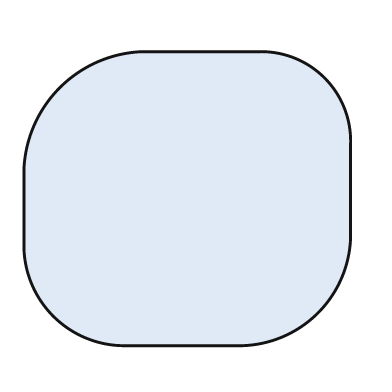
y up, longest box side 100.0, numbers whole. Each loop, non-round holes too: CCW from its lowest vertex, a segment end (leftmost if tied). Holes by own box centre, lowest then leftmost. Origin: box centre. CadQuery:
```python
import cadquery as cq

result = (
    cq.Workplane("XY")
    .moveTo(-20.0, -45.0)
    .lineTo(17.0, -45.0)
    .threePointArc((40.0, -35.0), (50.0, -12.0))
    .lineTo(50.0, 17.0)
    .threePointArc((42.0, 37.0), (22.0, 45.0))
    .lineTo(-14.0, 45.0)
    .threePointArc((-39.0, 34.0), (-50.0, 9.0))
    .lineTo(-50.0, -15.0)
    .threePointArc((-41.0, -36.0), (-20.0, -45.0))
    .close()
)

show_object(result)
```